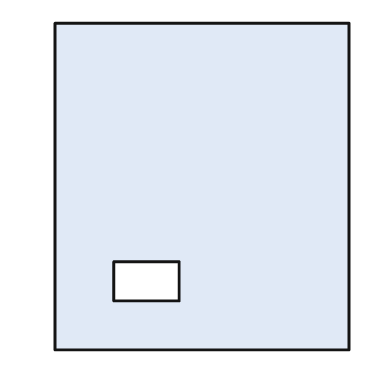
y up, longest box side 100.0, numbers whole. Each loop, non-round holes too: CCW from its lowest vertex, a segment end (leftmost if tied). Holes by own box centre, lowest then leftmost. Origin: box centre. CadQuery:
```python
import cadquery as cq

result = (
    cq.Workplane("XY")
    .moveTo(-45.0, -50.0)
    .lineTo(45.0, -50.0)
    .lineTo(45.0, 50.0)
    .lineTo(-45.0, 50.0)
    .close()
    .moveTo(-27.0, -35.0)
    .lineTo(-7.0, -35.0)
    .lineTo(-7.0, -23.0)
    .lineTo(-27.0, -23.0)
    .close()
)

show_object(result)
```